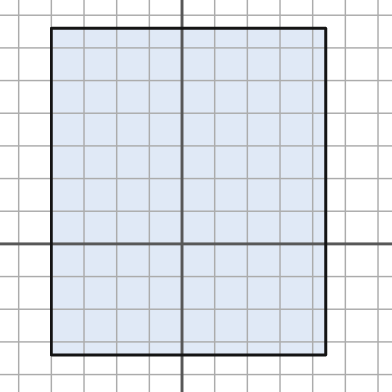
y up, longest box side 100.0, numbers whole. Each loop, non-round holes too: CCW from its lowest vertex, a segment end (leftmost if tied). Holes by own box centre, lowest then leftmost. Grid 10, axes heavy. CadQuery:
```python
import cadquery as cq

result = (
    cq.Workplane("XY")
    .moveTo(-40.0, -34.0)
    .lineTo(44.0, -34.0)
    .lineTo(44.0, 66.0)
    .lineTo(-40.0, 66.0)
    .close()
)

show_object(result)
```